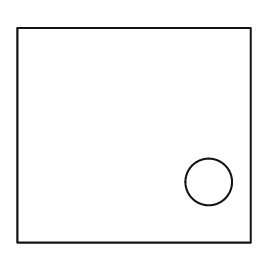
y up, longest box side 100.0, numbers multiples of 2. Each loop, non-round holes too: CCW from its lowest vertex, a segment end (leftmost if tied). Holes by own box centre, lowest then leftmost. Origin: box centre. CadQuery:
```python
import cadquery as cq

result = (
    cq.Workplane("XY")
    .moveTo(-50.0, -46.0)
    .lineTo(50.0, -46.0)
    .lineTo(50.0, 46.0)
    .lineTo(-50.0, 46.0)
    .close()
    .moveTo(32.0, -20.0)
    .circle(10.0)
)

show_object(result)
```